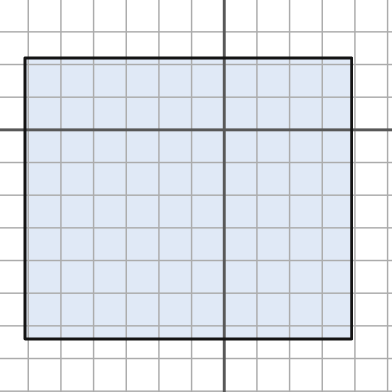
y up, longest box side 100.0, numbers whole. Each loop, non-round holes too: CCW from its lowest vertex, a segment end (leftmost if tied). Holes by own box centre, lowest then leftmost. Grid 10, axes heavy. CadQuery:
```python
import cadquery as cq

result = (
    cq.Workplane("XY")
    .moveTo(-61.0, -64.0)
    .lineTo(39.0, -64.0)
    .lineTo(39.0, 22.0)
    .lineTo(-61.0, 22.0)
    .close()
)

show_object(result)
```